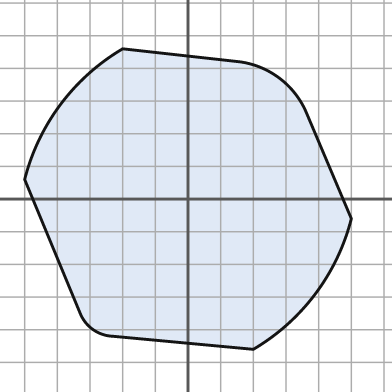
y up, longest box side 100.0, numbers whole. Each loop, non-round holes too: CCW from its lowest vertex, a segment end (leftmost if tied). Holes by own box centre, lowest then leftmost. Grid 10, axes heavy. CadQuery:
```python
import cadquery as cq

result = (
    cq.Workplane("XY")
    .moveTo(20.0, -46.0)
    .threePointArc((39.0, -29.0), (50.0, -6.0))
    .lineTo(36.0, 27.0)
    .threePointArc((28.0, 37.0), (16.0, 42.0))
    .lineTo(-20.0, 46.0)
    .threePointArc((-39.0, 29.0), (-50.0, 6.0))
    .lineTo(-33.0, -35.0)
    .threePointArc((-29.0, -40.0), (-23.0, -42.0))
    .close()
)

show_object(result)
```